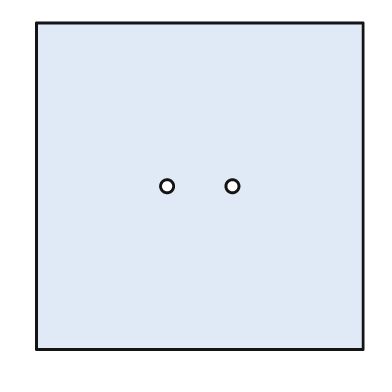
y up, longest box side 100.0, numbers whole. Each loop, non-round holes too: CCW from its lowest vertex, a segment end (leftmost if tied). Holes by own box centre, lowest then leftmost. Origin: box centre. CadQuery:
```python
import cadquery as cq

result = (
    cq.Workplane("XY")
    .moveTo(-50.0, -50.0)
    .lineTo(50.0, -50.0)
    .lineTo(50.0, 50.0)
    .lineTo(-50.0, 50.0)
    .close()
    .moveTo(-10.0, 0.0)
    .circle(2.0)
    .moveTo(10.0, 0.0)
    .circle(2.0)
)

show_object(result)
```